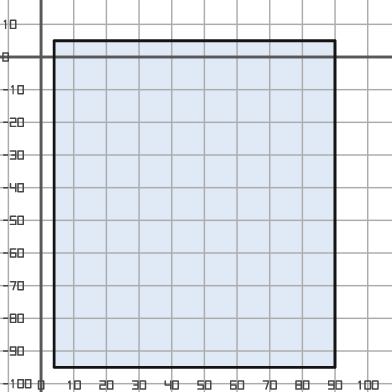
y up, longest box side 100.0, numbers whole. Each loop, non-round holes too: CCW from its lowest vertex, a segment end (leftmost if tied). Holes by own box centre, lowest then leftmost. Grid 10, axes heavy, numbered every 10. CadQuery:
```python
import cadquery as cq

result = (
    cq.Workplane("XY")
    .moveTo(4.0, -95.0)
    .lineTo(90.0, -95.0)
    .lineTo(90.0, 5.0)
    .lineTo(4.0, 5.0)
    .close()
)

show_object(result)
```